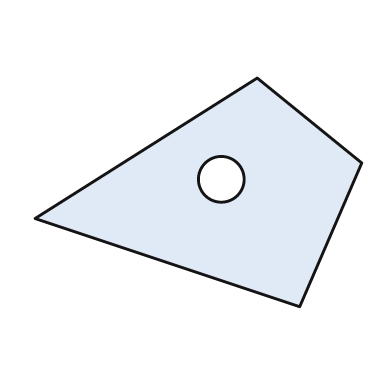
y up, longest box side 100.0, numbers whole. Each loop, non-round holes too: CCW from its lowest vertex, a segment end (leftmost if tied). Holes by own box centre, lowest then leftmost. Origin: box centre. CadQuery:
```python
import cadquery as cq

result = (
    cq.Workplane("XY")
    .moveTo(31.0, -35.0)
    .lineTo(50.0, 9.0)
    .lineTo(18.0, 35.0)
    .lineTo(-50.0, -8.0)
    .close()
    .moveTo(7.0, 4.0)
    .circle(7.0)
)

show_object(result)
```